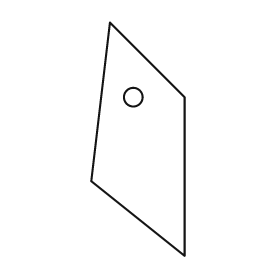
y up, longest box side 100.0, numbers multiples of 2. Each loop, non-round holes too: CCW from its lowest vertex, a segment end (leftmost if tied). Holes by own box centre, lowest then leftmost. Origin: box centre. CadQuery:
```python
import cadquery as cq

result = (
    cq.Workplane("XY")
    .moveTo(20.0, -50.0)
    .lineTo(20.0, 18.0)
    .lineTo(-12.0, 50.0)
    .lineTo(-20.0, -18.0)
    .close()
    .moveTo(-2.0, 18.0)
    .circle(4.0)
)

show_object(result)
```